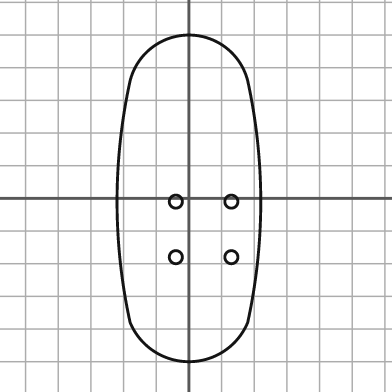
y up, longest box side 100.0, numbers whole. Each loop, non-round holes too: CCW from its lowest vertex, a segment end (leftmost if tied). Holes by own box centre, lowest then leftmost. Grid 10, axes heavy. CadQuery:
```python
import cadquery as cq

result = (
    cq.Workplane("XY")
    .moveTo(-18.0, -38.0)
    .threePointArc((0.0, -50.0), (18.0, -38.0))
    .threePointArc((22.0, -1.0), (18.0, 36.0))
    .threePointArc((0.0, 50.0), (-18.0, 36.0))
    .threePointArc((-22.0, -1.0), (-18.0, -38.0))
    .close()
    .moveTo(-4.0, -18.0)
    .circle(2.0)
    .moveTo(13.0, -18.0)
    .circle(2.0)
    .moveTo(-4.0, -1.0)
    .circle(2.0)
    .moveTo(13.0, -1.0)
    .circle(2.0)
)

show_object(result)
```